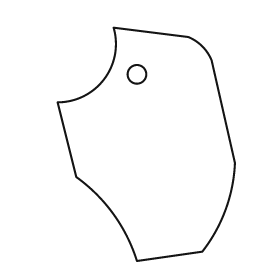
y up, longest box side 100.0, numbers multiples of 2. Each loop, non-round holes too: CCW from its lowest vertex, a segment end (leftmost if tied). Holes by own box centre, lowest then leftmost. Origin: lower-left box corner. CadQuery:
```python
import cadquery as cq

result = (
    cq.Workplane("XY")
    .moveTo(34.0, 0.0)
    .lineTo(62.0, 4.0)
    .threePointArc((72.0, 22.0), (76.0, 42.0))
    .lineTo(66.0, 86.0)
    .threePointArc((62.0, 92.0), (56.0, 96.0))
    .lineTo(24.0, 100.0)
    .threePointArc((20.0, 78.0), (0.0, 68.0))
    .lineTo(8.0, 36.0)
    .threePointArc((24.0, 20.0), (34.0, 0.0))
    .close()
    .moveTo(34.0, 80.0)
    .circle(4.0)
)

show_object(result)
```